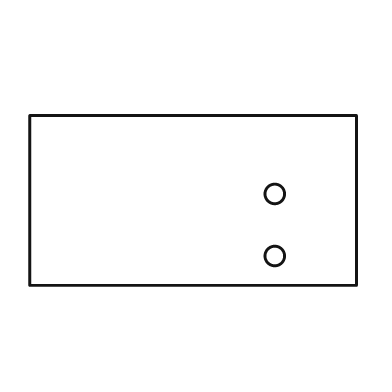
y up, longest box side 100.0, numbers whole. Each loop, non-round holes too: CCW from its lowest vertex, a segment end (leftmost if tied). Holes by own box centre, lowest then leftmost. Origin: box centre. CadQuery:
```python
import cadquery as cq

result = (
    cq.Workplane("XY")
    .moveTo(-50.0, -26.0)
    .lineTo(50.0, -26.0)
    .lineTo(50.0, 26.0)
    .lineTo(-50.0, 26.0)
    .close()
    .moveTo(25.0, -17.0)
    .circle(3.0)
    .moveTo(25.0, 2.0)
    .circle(3.0)
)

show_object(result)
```